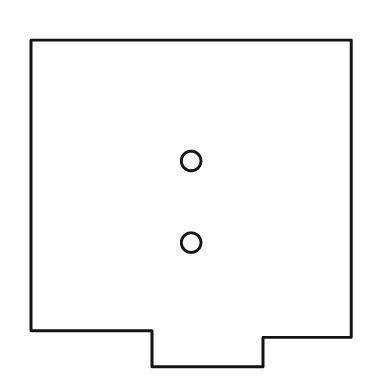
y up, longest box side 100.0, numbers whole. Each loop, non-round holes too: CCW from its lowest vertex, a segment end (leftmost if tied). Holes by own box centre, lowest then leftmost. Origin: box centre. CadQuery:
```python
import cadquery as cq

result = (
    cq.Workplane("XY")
    .moveTo(-12.0, -50.0)
    .lineTo(22.0, -50.0)
    .lineTo(22.0, -41.0)
    .lineTo(49.0, -41.0)
    .lineTo(49.0, 50.0)
    .lineTo(-49.0, 50.0)
    .lineTo(-49.0, -39.0)
    .lineTo(-12.0, -39.0)
    .close()
    .moveTo(0.0, -12.0)
    .circle(3.0)
    .moveTo(0.0, 13.0)
    .circle(3.0)
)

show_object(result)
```